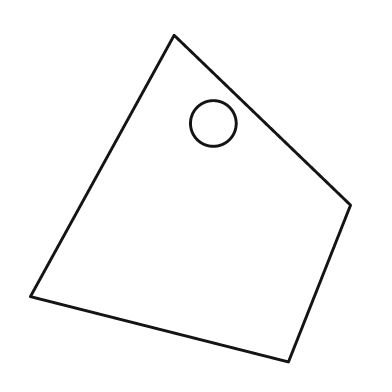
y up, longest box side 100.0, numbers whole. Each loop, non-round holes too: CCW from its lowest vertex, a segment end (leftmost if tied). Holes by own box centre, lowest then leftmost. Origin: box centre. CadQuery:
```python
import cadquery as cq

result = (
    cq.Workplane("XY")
    .moveTo(30.0, -50.0)
    .lineTo(49.0, -2.0)
    .lineTo(-5.0, 50.0)
    .lineTo(-49.0, -30.0)
    .close()
    .moveTo(7.0, 23.0)
    .circle(7.0)
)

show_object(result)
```